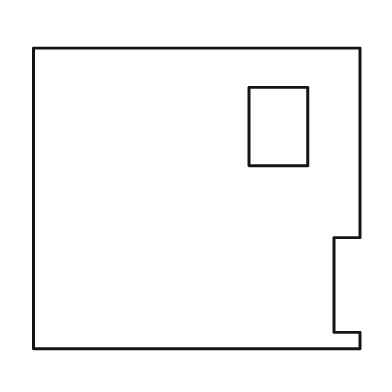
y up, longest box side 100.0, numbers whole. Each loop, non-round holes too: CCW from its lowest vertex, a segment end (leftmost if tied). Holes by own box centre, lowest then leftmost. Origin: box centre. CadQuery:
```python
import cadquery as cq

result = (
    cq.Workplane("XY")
    .moveTo(-50.0, -46.0)
    .lineTo(50.0, -46.0)
    .lineTo(50.0, -41.0)
    .lineTo(42.0, -41.0)
    .lineTo(42.0, -12.0)
    .lineTo(50.0, -12.0)
    .lineTo(50.0, 46.0)
    .lineTo(-50.0, 46.0)
    .close()
    .moveTo(16.0, 10.0)
    .lineTo(34.0, 10.0)
    .lineTo(34.0, 34.0)
    .lineTo(16.0, 34.0)
    .close()
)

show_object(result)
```